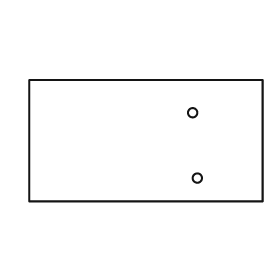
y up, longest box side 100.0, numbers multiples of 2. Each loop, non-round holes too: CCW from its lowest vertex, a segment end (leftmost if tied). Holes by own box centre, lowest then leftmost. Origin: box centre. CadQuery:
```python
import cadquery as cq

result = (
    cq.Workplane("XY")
    .moveTo(-50.0, -26.0)
    .lineTo(50.0, -26.0)
    .lineTo(50.0, 26.0)
    .lineTo(-50.0, 26.0)
    .close()
    .moveTo(22.0, -16.0)
    .circle(2.0)
    .moveTo(20.0, 12.0)
    .circle(2.0)
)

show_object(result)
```